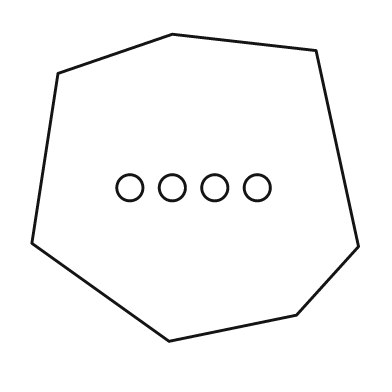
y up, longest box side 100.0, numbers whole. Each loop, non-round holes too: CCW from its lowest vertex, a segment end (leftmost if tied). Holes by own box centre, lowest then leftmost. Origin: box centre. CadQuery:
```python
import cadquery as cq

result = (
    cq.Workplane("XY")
    .moveTo(-8.0, -47.0)
    .lineTo(31.0, -39.0)
    .lineTo(50.0, -18.0)
    .lineTo(37.0, 42.0)
    .lineTo(-7.0, 47.0)
    .lineTo(-42.0, 35.0)
    .lineTo(-50.0, -17.0)
    .close()
    .moveTo(-20.0, 0.0)
    .circle(4.0)
    .moveTo(-7.0, 0.0)
    .circle(4.0)
    .moveTo(6.0, 0.0)
    .circle(4.0)
    .moveTo(19.0, 0.0)
    .circle(4.0)
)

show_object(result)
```